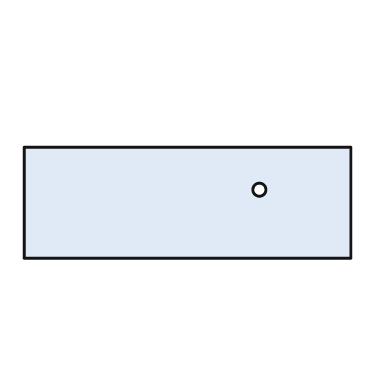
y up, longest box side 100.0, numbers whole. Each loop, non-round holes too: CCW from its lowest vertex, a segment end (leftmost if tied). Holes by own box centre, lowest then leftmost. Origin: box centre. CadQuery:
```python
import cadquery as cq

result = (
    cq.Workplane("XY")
    .moveTo(-50.0, -17.0)
    .lineTo(50.0, -17.0)
    .lineTo(50.0, 17.0)
    .lineTo(-50.0, 17.0)
    .close()
    .moveTo(22.0, 4.0)
    .circle(2.0)
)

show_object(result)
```